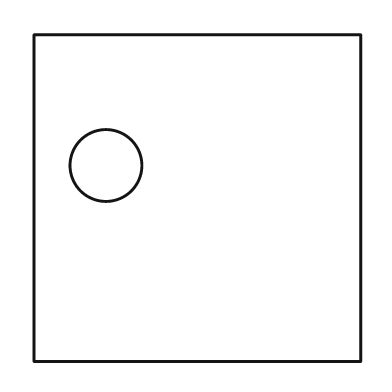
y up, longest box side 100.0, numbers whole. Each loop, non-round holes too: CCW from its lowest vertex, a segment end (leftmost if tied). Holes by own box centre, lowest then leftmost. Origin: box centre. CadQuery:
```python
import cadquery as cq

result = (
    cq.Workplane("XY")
    .moveTo(-50.0, -50.0)
    .lineTo(50.0, -50.0)
    .lineTo(50.0, 50.0)
    .lineTo(-50.0, 50.0)
    .close()
    .moveTo(-28.0, 10.0)
    .circle(11.0)
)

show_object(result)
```